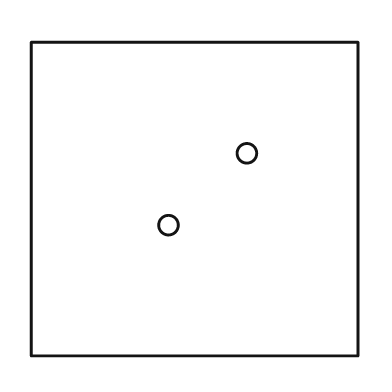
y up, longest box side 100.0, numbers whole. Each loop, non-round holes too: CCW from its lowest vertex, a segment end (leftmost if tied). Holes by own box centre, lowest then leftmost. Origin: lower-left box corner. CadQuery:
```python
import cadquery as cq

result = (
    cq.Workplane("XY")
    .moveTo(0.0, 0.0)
    .lineTo(100.0, 0.0)
    .lineTo(100.0, 96.0)
    .lineTo(0.0, 96.0)
    .close()
    .moveTo(42.0, 40.0)
    .circle(3.0)
    .moveTo(66.0, 62.0)
    .circle(3.0)
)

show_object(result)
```